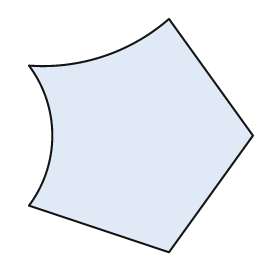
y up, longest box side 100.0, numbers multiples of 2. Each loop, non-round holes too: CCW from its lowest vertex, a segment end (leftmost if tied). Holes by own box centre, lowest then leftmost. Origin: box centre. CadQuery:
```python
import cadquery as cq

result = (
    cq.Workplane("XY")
    .moveTo(12.0, -50.0)
    .lineTo(48.0, 0.0)
    .lineTo(12.0, 50.0)
    .threePointArc((-16.0, 34.0), (-48.0, 30.0))
    .threePointArc((-38.0, 0.0), (-48.0, -30.0))
    .close()
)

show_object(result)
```